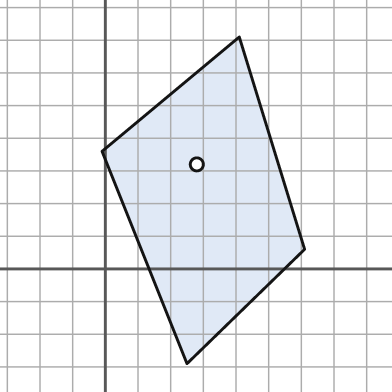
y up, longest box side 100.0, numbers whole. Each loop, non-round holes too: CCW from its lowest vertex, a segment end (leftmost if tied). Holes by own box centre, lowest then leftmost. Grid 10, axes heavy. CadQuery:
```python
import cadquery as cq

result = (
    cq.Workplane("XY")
    .moveTo(25.0, -29.0)
    .lineTo(61.0, 6.0)
    .lineTo(41.0, 71.0)
    .lineTo(-1.0, 36.0)
    .close()
    .moveTo(28.0, 32.0)
    .circle(2.0)
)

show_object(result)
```